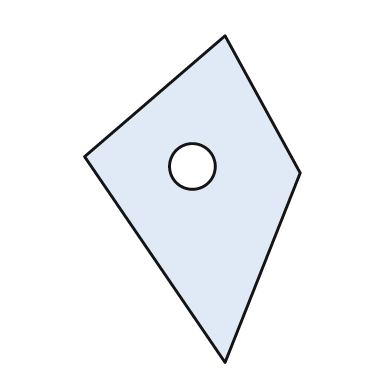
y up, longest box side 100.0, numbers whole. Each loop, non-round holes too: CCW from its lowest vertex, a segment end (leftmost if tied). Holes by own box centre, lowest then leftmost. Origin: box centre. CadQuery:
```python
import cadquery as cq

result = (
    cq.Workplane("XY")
    .moveTo(10.0, -50.0)
    .lineTo(33.0, 8.0)
    .lineTo(10.0, 50.0)
    .lineTo(-33.0, 13.0)
    .close()
    .moveTo(0.0, 10.0)
    .circle(7.0)
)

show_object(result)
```